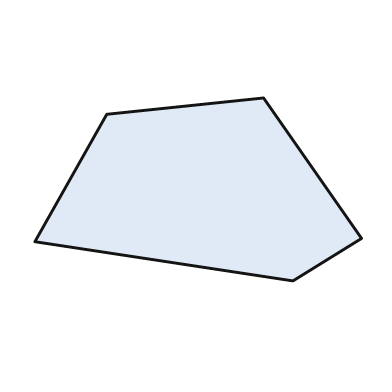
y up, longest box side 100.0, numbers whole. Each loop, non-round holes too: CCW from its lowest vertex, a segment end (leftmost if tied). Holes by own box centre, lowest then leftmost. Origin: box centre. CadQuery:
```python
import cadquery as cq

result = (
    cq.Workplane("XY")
    .moveTo(29.0, -28.0)
    .lineTo(50.0, -15.0)
    .lineTo(20.0, 28.0)
    .lineTo(-28.0, 23.0)
    .lineTo(-50.0, -16.0)
    .close()
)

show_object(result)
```